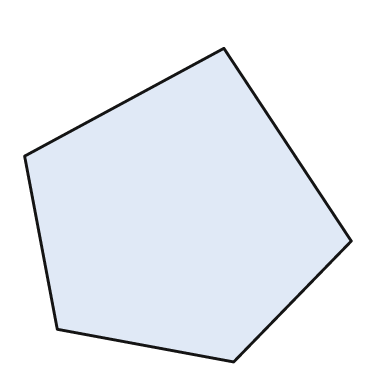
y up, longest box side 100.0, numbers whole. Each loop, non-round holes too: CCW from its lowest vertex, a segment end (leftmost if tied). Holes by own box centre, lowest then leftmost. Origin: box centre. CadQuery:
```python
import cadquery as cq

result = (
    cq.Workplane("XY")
    .moveTo(14.0, -48.0)
    .lineTo(50.0, -11.0)
    .lineTo(11.0, 48.0)
    .lineTo(-50.0, 15.0)
    .lineTo(-40.0, -38.0)
    .close()
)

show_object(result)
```